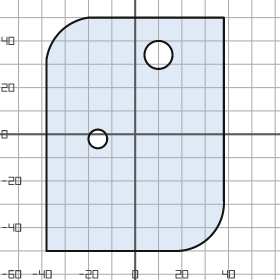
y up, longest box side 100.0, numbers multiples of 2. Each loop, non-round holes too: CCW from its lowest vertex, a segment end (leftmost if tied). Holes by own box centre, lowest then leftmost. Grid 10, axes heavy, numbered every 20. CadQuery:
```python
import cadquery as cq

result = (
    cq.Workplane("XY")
    .moveTo(-38.0, -50.0)
    .lineTo(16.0, -50.0)
    .threePointArc((32.0, -44.0), (38.0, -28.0))
    .lineTo(38.0, 50.0)
    .lineTo(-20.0, 50.0)
    .threePointArc((-32.0, 44.0), (-38.0, 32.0))
    .close()
    .moveTo(-16.0, -2.0)
    .circle(4.0)
    .moveTo(10.0, 34.0)
    .circle(6.0)
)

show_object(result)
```